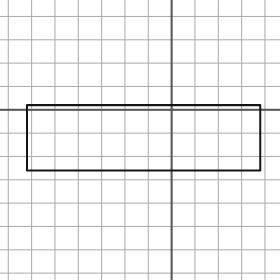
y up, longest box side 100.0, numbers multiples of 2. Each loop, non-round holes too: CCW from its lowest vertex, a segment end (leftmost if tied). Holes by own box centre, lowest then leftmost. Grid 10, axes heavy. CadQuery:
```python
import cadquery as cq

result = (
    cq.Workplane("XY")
    .moveTo(-62.0, -26.0)
    .lineTo(38.0, -26.0)
    .lineTo(38.0, 2.0)
    .lineTo(-62.0, 2.0)
    .close()
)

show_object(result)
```